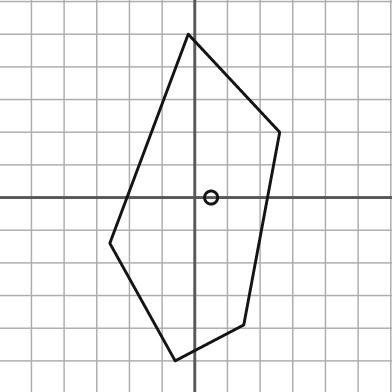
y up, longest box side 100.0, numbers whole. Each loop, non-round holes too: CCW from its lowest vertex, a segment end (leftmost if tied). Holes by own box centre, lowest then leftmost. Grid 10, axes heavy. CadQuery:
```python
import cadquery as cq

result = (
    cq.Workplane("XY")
    .moveTo(-6.0, -50.0)
    .lineTo(15.0, -39.0)
    .lineTo(26.0, 20.0)
    .lineTo(-2.0, 50.0)
    .lineTo(-26.0, -14.0)
    .close()
    .moveTo(5.0, 0.0)
    .circle(2.0)
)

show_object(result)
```